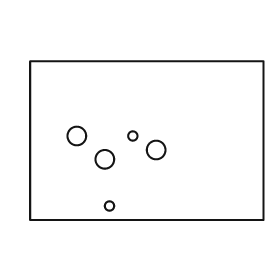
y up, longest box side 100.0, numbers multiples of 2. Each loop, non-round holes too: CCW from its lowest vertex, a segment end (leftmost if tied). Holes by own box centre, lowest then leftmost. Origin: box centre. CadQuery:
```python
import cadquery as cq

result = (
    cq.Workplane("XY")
    .moveTo(-50.0, -34.0)
    .lineTo(50.0, -34.0)
    .lineTo(50.0, 34.0)
    .lineTo(-50.0, 34.0)
    .close()
    .moveTo(-16.0, -28.0)
    .circle(2.0)
    .moveTo(-18.0, -8.0)
    .circle(4.0)
    .moveTo(4.0, -4.0)
    .circle(4.0)
    .moveTo(-30.0, 2.0)
    .circle(4.0)
    .moveTo(-6.0, 2.0)
    .circle(2.0)
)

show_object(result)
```